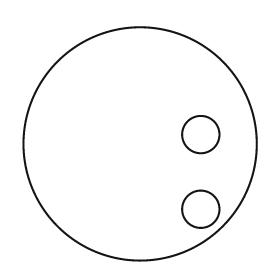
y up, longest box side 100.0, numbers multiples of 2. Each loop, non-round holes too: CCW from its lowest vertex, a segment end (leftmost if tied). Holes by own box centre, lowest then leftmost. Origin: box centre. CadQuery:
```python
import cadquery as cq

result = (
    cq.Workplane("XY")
    .moveTo(0.0, 0.0)
    .circle(50.0)
    .moveTo(26.0, -28.0)
    .circle(8.0)
    .moveTo(26.0, 4.0)
    .circle(8.0)
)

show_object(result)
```